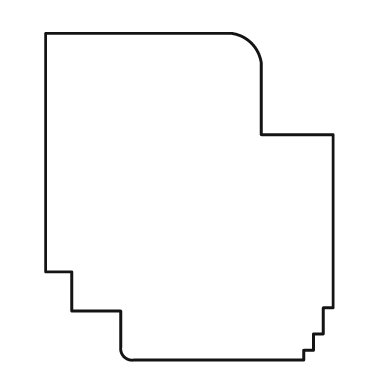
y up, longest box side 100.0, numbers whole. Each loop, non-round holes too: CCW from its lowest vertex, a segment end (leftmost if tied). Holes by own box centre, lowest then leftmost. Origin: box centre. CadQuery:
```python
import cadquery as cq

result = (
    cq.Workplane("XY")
    .moveTo(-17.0, -50.0)
    .lineTo(35.0, -50.0)
    .lineTo(35.0, -47.0)
    .lineTo(38.0, -47.0)
    .lineTo(38.0, -42.0)
    .lineTo(41.0, -42.0)
    .lineTo(41.0, -34.0)
    .lineTo(44.0, -34.0)
    .lineTo(44.0, 19.0)
    .lineTo(22.0, 19.0)
    .lineTo(22.0, 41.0)
    .threePointArc((19.0, 47.0), (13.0, 50.0))
    .lineTo(-44.0, 50.0)
    .lineTo(-44.0, -23.0)
    .lineTo(-36.0, -23.0)
    .lineTo(-36.0, -35.0)
    .lineTo(-21.0, -35.0)
    .lineTo(-21.0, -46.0)
    .threePointArc((-20.0, -49.0), (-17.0, -50.0))
    .close()
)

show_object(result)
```